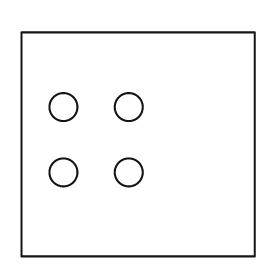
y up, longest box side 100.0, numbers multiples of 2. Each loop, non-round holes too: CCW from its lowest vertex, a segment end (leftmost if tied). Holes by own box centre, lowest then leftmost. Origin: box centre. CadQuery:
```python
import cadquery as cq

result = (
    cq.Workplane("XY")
    .moveTo(-50.0, -48.0)
    .lineTo(50.0, -48.0)
    .lineTo(50.0, 48.0)
    .lineTo(-50.0, 48.0)
    .close()
    .moveTo(-32.0, -12.0)
    .circle(6.0)
    .moveTo(-4.0, -12.0)
    .circle(6.0)
    .moveTo(-32.0, 16.0)
    .circle(6.0)
    .moveTo(-4.0, 16.0)
    .circle(6.0)
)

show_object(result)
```